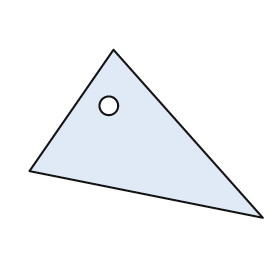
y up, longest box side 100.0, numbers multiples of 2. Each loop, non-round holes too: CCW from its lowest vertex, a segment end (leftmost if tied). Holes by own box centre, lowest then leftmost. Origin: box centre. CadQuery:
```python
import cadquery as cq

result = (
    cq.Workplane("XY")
    .moveTo(50.0, -36.0)
    .lineTo(-14.0, 36.0)
    .lineTo(-50.0, -16.0)
    .close()
    .moveTo(-16.0, 12.0)
    .circle(4.0)
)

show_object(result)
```